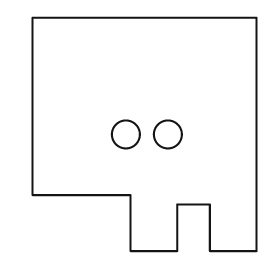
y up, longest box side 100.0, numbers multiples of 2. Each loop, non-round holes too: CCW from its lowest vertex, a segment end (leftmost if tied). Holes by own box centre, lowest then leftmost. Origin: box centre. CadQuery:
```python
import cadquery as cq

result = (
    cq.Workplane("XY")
    .moveTo(-6.0, -50.0)
    .lineTo(14.0, -50.0)
    .lineTo(14.0, -30.0)
    .lineTo(28.0, -30.0)
    .lineTo(28.0, -50.0)
    .lineTo(48.0, -50.0)
    .lineTo(48.0, 50.0)
    .lineTo(-48.0, 50.0)
    .lineTo(-48.0, -26.0)
    .lineTo(-6.0, -26.0)
    .close()
    .moveTo(-8.0, 0.0)
    .circle(6.0)
    .moveTo(10.0, 0.0)
    .circle(6.0)
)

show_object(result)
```